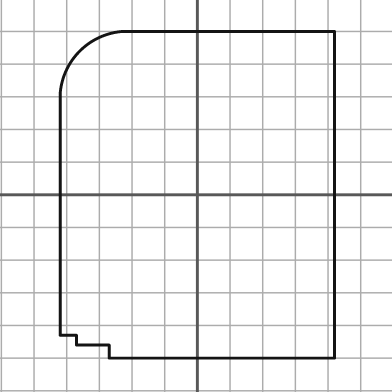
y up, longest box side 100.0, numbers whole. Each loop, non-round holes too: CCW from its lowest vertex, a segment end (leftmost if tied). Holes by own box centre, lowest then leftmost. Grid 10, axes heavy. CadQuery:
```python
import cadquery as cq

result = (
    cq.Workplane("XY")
    .moveTo(-27.0, -50.0)
    .lineTo(42.0, -50.0)
    .lineTo(42.0, 50.0)
    .lineTo(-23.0, 50.0)
    .threePointArc((-36.0, 44.0), (-42.0, 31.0))
    .lineTo(-42.0, -43.0)
    .lineTo(-37.0, -43.0)
    .lineTo(-37.0, -46.0)
    .lineTo(-27.0, -46.0)
    .close()
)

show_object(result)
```